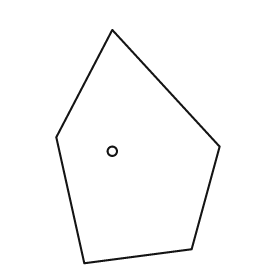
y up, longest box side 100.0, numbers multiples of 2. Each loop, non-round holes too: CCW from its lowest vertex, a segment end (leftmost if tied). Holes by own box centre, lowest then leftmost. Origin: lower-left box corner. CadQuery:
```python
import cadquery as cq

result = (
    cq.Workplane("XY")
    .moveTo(12.0, 0.0)
    .lineTo(58.0, 6.0)
    .lineTo(70.0, 50.0)
    .lineTo(24.0, 100.0)
    .lineTo(0.0, 54.0)
    .close()
    .moveTo(24.0, 48.0)
    .circle(2.0)
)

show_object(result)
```